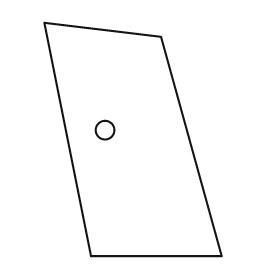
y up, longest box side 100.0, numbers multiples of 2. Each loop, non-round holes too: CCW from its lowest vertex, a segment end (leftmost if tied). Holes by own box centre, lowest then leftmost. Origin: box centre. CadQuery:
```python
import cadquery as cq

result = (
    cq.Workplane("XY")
    .moveTo(-18.0, -50.0)
    .lineTo(38.0, -50.0)
    .lineTo(12.0, 44.0)
    .lineTo(-38.0, 50.0)
    .close()
    .moveTo(-12.0, 4.0)
    .circle(4.0)
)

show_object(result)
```